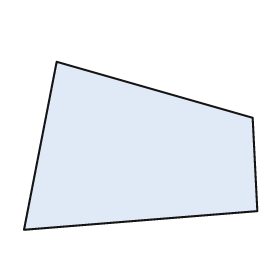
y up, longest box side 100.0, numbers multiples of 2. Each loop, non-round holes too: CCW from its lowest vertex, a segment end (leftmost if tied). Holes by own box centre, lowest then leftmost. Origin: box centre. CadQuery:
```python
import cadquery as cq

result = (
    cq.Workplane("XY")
    .moveTo(-50.0, -36.0)
    .lineTo(50.0, -28.0)
    .lineTo(48.0, 12.0)
    .lineTo(-36.0, 36.0)
    .close()
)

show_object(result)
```